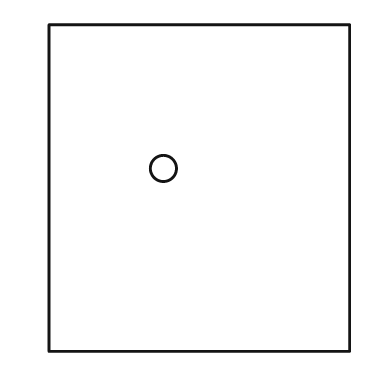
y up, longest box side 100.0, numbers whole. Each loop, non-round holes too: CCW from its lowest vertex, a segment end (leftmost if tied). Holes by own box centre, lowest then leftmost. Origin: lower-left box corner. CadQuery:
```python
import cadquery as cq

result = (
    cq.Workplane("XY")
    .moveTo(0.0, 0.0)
    .lineTo(92.0, 0.0)
    .lineTo(92.0, 100.0)
    .lineTo(0.0, 100.0)
    .close()
    .moveTo(35.0, 56.0)
    .circle(4.0)
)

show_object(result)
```